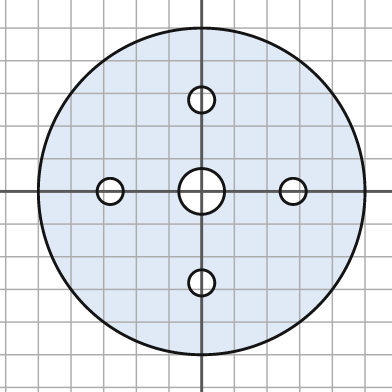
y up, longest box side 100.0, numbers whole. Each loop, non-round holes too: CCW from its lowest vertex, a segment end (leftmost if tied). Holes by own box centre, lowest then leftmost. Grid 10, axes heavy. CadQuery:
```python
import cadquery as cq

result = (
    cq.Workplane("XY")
    .moveTo(0.0, 0.0)
    .circle(50.0)
    .moveTo(0.0, -28.0)
    .circle(4.0)
    .moveTo(-28.0, 0.0)
    .circle(4.0)
    .moveTo(0.0, 0.0)
    .circle(7.0)
    .moveTo(28.0, 0.0)
    .circle(4.0)
    .moveTo(0.0, 28.0)
    .circle(4.0)
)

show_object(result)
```